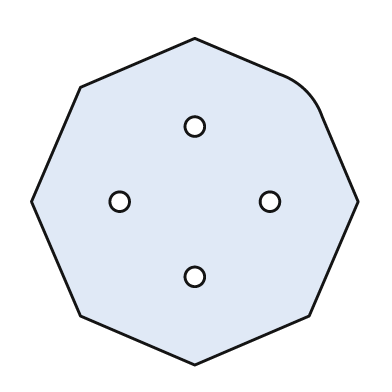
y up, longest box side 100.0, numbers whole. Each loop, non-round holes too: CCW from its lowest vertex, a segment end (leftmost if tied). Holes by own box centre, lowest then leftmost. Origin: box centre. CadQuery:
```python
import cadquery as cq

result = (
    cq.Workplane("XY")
    .moveTo(0.0, -50.0)
    .lineTo(35.0, -35.0)
    .lineTo(50.0, 0.0)
    .lineTo(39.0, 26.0)
    .threePointArc((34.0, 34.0), (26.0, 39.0))
    .lineTo(0.0, 50.0)
    .lineTo(-35.0, 35.0)
    .lineTo(-50.0, 0.0)
    .lineTo(-35.0, -35.0)
    .close()
    .moveTo(0.0, -23.0)
    .circle(3.0)
    .moveTo(-23.0, 0.0)
    .circle(3.0)
    .moveTo(23.0, 0.0)
    .circle(3.0)
    .moveTo(0.0, 23.0)
    .circle(3.0)
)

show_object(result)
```